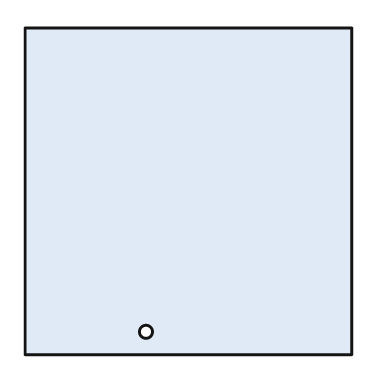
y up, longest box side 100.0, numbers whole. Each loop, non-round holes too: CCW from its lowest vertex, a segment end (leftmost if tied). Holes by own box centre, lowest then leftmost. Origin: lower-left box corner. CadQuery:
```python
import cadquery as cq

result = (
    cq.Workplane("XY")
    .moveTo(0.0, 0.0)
    .lineTo(100.0, 0.0)
    .lineTo(100.0, 100.0)
    .lineTo(0.0, 100.0)
    .close()
    .moveTo(37.0, 7.0)
    .circle(2.0)
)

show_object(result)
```